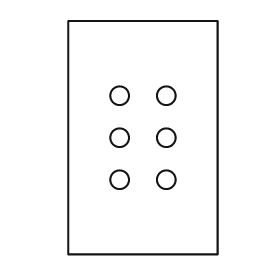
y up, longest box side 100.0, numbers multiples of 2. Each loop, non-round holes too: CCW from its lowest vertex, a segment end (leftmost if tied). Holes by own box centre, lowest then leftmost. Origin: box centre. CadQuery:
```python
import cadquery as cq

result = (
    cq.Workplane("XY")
    .moveTo(-32.0, -50.0)
    .lineTo(32.0, -50.0)
    .lineTo(32.0, 50.0)
    .lineTo(-32.0, 50.0)
    .close()
    .moveTo(-10.0, -18.0)
    .circle(4.0)
    .moveTo(10.0, -18.0)
    .circle(4.0)
    .moveTo(-10.0, 0.0)
    .circle(4.0)
    .moveTo(10.0, 0.0)
    .circle(4.0)
    .moveTo(-10.0, 18.0)
    .circle(4.0)
    .moveTo(10.0, 18.0)
    .circle(4.0)
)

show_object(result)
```